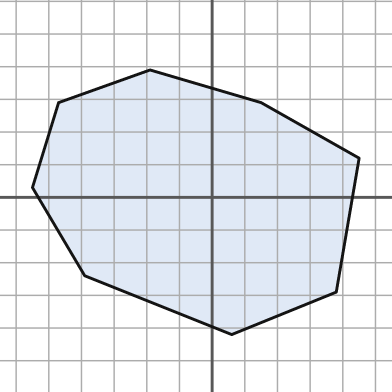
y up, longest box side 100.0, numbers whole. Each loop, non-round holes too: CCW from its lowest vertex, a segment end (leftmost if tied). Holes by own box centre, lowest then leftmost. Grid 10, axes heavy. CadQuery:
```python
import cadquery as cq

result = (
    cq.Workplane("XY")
    .moveTo(6.0, -42.0)
    .lineTo(38.0, -29.0)
    .lineTo(45.0, 12.0)
    .lineTo(15.0, 29.0)
    .lineTo(-19.0, 39.0)
    .lineTo(-47.0, 29.0)
    .lineTo(-55.0, 3.0)
    .lineTo(-39.0, -24.0)
    .close()
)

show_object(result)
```